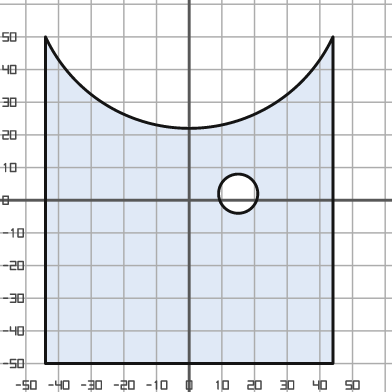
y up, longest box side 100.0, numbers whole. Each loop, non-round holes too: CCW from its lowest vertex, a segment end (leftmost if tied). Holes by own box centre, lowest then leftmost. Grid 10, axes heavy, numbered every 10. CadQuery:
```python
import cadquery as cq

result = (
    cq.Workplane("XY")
    .moveTo(-44.0, -50.0)
    .lineTo(44.0, -50.0)
    .lineTo(44.0, 50.0)
    .threePointArc((0.0, 22.0), (-44.0, 50.0))
    .close()
    .moveTo(15.0, 2.0)
    .circle(6.0)
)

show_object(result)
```